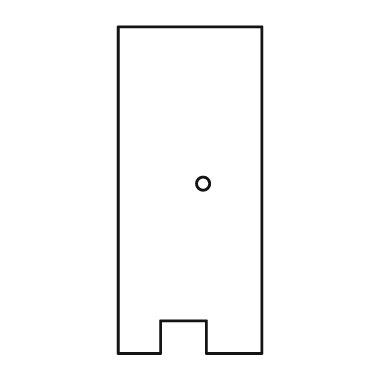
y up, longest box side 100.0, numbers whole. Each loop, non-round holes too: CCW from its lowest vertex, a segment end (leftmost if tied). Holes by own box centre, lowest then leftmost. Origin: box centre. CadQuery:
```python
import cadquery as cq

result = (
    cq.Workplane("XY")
    .moveTo(-22.0, -50.0)
    .lineTo(-9.0, -50.0)
    .lineTo(-9.0, -40.0)
    .lineTo(5.0, -40.0)
    .lineTo(5.0, -50.0)
    .lineTo(22.0, -50.0)
    .lineTo(22.0, 50.0)
    .lineTo(-22.0, 50.0)
    .close()
    .moveTo(4.0, 2.0)
    .circle(2.0)
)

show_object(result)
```